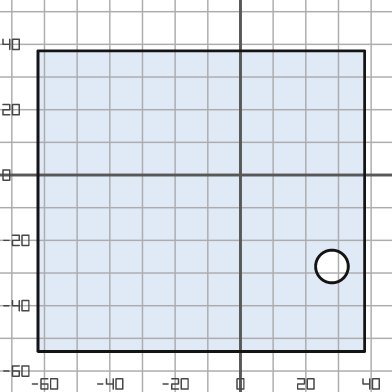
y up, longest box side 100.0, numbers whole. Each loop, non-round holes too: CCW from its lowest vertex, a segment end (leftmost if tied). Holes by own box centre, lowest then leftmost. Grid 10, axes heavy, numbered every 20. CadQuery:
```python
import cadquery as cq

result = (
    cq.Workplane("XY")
    .moveTo(-62.0, -54.0)
    .lineTo(38.0, -54.0)
    .lineTo(38.0, 38.0)
    .lineTo(-62.0, 38.0)
    .close()
    .moveTo(28.0, -28.0)
    .circle(5.0)
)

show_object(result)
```